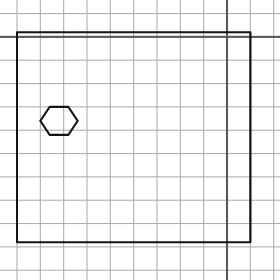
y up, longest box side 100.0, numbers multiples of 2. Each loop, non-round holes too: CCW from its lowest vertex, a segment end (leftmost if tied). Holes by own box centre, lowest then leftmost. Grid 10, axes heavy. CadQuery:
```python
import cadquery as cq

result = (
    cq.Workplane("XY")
    .moveTo(-90.0, -88.0)
    .lineTo(10.0, -88.0)
    .lineTo(10.0, 2.0)
    .lineTo(-90.0, 2.0)
    .close()
    .moveTo(-76.0, -42.0)
    .lineTo(-68.0, -42.0)
    .lineTo(-64.0, -36.0)
    .lineTo(-68.0, -30.0)
    .lineTo(-76.0, -30.0)
    .lineTo(-80.0, -36.0)
    .close()
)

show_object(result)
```